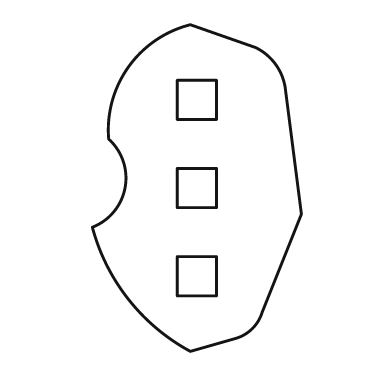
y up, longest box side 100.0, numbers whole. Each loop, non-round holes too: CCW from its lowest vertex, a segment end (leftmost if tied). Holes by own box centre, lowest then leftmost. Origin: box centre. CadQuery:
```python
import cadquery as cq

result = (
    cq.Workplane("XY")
    .moveTo(-2.0, -50.0)
    .lineTo(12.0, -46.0)
    .threePointArc((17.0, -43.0), (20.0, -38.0))
    .lineTo(32.0, -8.0)
    .lineTo(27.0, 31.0)
    .threePointArc((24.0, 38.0), (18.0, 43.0))
    .lineTo(-2.0, 50.0)
    .threePointArc((-21.0, 37.0), (-27.0, 15.0))
    .threePointArc((-22.0, 0.0), (-32.0, -12.0))
    .threePointArc((-21.0, -34.0), (-2.0, -50.0))
    .close()
    .moveTo(-6.0, -33.0)
    .lineTo(6.0, -33.0)
    .lineTo(6.0, -21.0)
    .lineTo(-6.0, -21.0)
    .close()
    .moveTo(-6.0, -6.0)
    .lineTo(6.0, -6.0)
    .lineTo(6.0, 6.0)
    .lineTo(-6.0, 6.0)
    .close()
    .moveTo(-6.0, 21.0)
    .lineTo(6.0, 21.0)
    .lineTo(6.0, 33.0)
    .lineTo(-6.0, 33.0)
    .close()
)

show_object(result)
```